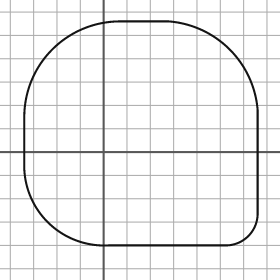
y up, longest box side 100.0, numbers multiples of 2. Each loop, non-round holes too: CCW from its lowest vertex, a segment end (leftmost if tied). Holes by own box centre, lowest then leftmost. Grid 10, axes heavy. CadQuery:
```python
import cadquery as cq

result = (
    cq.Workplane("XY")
    .moveTo(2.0, -40.0)
    .lineTo(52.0, -40.0)
    .threePointArc((62.0, -36.0), (66.0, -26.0))
    .lineTo(66.0, 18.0)
    .threePointArc((54.0, 44.0), (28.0, 56.0))
    .lineTo(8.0, 56.0)
    .threePointArc((-22.0, 44.0), (-34.0, 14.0))
    .lineTo(-34.0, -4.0)
    .threePointArc((-24.0, -30.0), (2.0, -40.0))
    .close()
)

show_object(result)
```